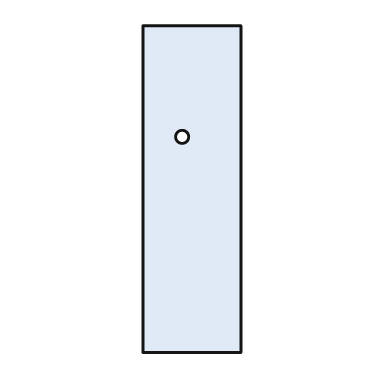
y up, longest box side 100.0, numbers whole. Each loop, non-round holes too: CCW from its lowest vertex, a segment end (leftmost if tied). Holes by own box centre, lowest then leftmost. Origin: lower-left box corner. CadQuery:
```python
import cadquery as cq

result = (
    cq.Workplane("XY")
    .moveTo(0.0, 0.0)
    .lineTo(30.0, 0.0)
    .lineTo(30.0, 100.0)
    .lineTo(0.0, 100.0)
    .close()
    .moveTo(12.0, 66.0)
    .circle(2.0)
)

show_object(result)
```